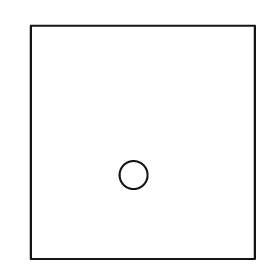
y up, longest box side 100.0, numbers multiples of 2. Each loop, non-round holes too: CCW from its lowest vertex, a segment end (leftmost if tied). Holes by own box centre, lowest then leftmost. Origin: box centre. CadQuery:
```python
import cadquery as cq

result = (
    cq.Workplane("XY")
    .moveTo(-48.0, -50.0)
    .lineTo(48.0, -50.0)
    .lineTo(48.0, 50.0)
    .lineTo(-48.0, 50.0)
    .close()
    .moveTo(-4.0, -14.0)
    .circle(6.0)
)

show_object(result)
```